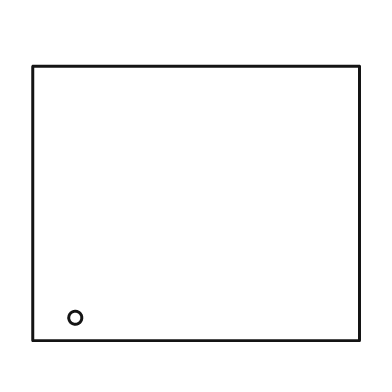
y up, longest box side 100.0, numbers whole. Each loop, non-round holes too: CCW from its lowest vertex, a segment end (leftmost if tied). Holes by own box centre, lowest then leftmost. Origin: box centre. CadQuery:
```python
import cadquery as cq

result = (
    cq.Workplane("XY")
    .moveTo(-50.0, -42.0)
    .lineTo(50.0, -42.0)
    .lineTo(50.0, 42.0)
    .lineTo(-50.0, 42.0)
    .close()
    .moveTo(-37.0, -35.0)
    .circle(2.0)
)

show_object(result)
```